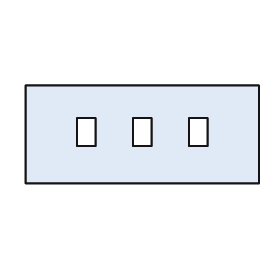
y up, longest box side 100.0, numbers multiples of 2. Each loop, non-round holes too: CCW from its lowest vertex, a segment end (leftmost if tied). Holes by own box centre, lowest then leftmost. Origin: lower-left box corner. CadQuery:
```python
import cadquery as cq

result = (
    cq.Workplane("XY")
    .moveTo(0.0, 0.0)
    .lineTo(100.0, 0.0)
    .lineTo(100.0, 42.0)
    .lineTo(0.0, 42.0)
    .close()
    .moveTo(22.0, 16.0)
    .lineTo(30.0, 16.0)
    .lineTo(30.0, 28.0)
    .lineTo(22.0, 28.0)
    .close()
    .moveTo(46.0, 16.0)
    .lineTo(54.0, 16.0)
    .lineTo(54.0, 28.0)
    .lineTo(46.0, 28.0)
    .close()
    .moveTo(70.0, 16.0)
    .lineTo(78.0, 16.0)
    .lineTo(78.0, 28.0)
    .lineTo(70.0, 28.0)
    .close()
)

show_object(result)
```